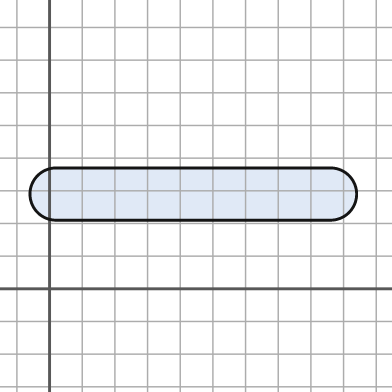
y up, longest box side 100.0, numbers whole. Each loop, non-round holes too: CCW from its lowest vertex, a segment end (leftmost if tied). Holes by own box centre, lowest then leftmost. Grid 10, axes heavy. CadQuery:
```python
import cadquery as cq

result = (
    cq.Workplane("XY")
    .moveTo(2.0, 21.0)
    .lineTo(86.0, 21.0)
    .threePointArc((94.0, 29.0), (86.0, 37.0))
    .lineTo(2.0, 37.0)
    .threePointArc((-6.0, 29.0), (2.0, 21.0))
    .close()
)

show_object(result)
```